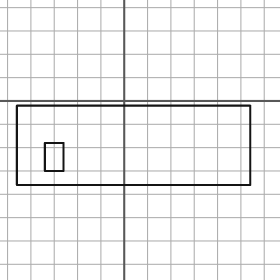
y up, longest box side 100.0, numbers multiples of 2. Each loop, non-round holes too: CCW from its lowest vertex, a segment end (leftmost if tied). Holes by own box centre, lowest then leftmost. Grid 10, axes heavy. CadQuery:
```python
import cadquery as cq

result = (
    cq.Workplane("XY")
    .moveTo(-46.0, -36.0)
    .lineTo(54.0, -36.0)
    .lineTo(54.0, -2.0)
    .lineTo(-46.0, -2.0)
    .close()
    .moveTo(-34.0, -30.0)
    .lineTo(-26.0, -30.0)
    .lineTo(-26.0, -18.0)
    .lineTo(-34.0, -18.0)
    .close()
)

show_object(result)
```